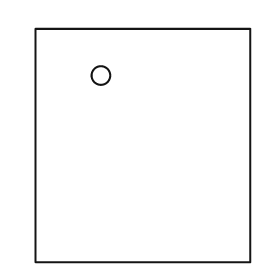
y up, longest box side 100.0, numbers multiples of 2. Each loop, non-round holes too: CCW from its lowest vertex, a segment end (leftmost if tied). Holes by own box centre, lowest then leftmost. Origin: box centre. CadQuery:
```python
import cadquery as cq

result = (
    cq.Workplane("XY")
    .moveTo(-46.0, -50.0)
    .lineTo(46.0, -50.0)
    .lineTo(46.0, 50.0)
    .lineTo(-46.0, 50.0)
    .close()
    .moveTo(-18.0, 30.0)
    .circle(4.0)
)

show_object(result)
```